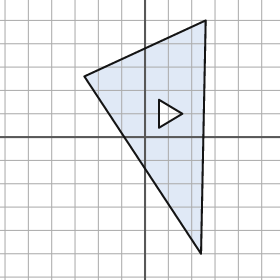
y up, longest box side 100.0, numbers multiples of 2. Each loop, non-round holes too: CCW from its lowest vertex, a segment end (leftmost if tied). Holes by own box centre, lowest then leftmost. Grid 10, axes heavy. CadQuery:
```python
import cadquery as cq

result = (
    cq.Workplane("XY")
    .moveTo(24.0, -50.0)
    .lineTo(26.0, 50.0)
    .lineTo(-26.0, 26.0)
    .close()
    .moveTo(6.0, 4.0)
    .lineTo(16.0, 10.0)
    .lineTo(6.0, 16.0)
    .close()
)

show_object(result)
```